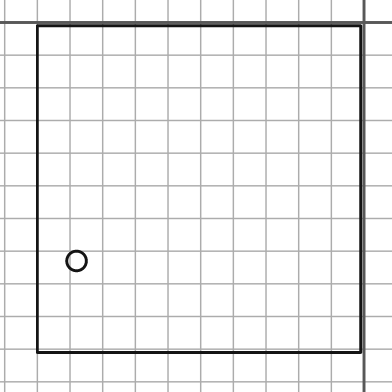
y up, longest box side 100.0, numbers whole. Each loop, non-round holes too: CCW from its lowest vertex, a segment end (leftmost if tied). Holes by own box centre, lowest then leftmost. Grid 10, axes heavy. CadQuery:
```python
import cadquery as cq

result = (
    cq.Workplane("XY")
    .moveTo(-100.0, -101.0)
    .lineTo(-1.0, -101.0)
    .lineTo(-1.0, -1.0)
    .lineTo(-100.0, -1.0)
    .close()
    .moveTo(-88.0, -73.0)
    .circle(3.0)
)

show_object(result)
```